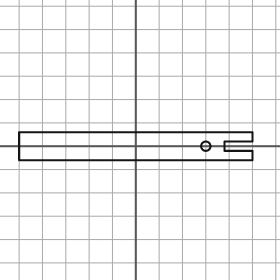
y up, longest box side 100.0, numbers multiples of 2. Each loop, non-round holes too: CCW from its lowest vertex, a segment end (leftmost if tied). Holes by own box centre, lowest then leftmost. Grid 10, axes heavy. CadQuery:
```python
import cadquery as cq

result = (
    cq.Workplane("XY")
    .moveTo(-50.0, -6.0)
    .lineTo(50.0, -6.0)
    .lineTo(50.0, -2.0)
    .lineTo(38.0, -2.0)
    .lineTo(38.0, 2.0)
    .lineTo(50.0, 2.0)
    .lineTo(50.0, 6.0)
    .lineTo(-50.0, 6.0)
    .close()
    .moveTo(30.0, 0.0)
    .circle(2.0)
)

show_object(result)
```